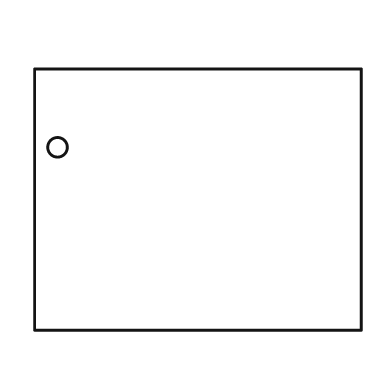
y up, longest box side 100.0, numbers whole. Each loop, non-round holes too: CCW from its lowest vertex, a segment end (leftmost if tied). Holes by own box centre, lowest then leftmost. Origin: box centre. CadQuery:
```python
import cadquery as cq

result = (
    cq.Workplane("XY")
    .moveTo(-50.0, -40.0)
    .lineTo(50.0, -40.0)
    .lineTo(50.0, 40.0)
    .lineTo(-50.0, 40.0)
    .close()
    .moveTo(-43.0, 16.0)
    .circle(3.0)
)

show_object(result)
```